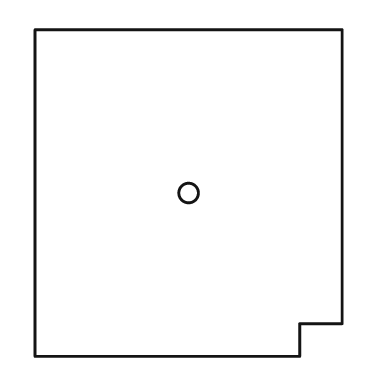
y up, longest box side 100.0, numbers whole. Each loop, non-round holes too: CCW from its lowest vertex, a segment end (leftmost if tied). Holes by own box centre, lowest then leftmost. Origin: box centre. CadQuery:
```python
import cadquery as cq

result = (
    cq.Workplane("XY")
    .moveTo(-47.0, -50.0)
    .lineTo(34.0, -50.0)
    .lineTo(34.0, -40.0)
    .lineTo(47.0, -40.0)
    .lineTo(47.0, 50.0)
    .lineTo(-47.0, 50.0)
    .close()
    .moveTo(0.0, 0.0)
    .circle(3.0)
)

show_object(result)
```